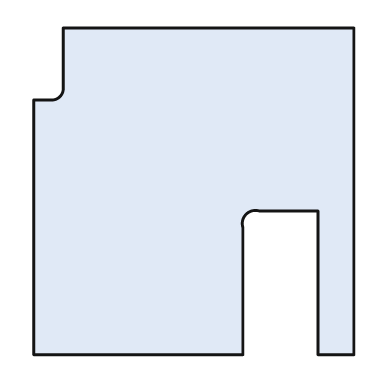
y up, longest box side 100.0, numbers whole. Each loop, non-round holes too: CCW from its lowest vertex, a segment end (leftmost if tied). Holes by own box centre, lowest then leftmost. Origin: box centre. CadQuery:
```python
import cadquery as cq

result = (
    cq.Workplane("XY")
    .moveTo(-49.0, -50.0)
    .lineTo(15.0, -50.0)
    .lineTo(15.0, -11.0)
    .threePointArc((16.0, -7.0), (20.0, -6.0))
    .lineTo(38.0, -6.0)
    .lineTo(38.0, -50.0)
    .lineTo(49.0, -50.0)
    .lineTo(49.0, 50.0)
    .lineTo(-40.0, 50.0)
    .lineTo(-40.0, 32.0)
    .threePointArc((-41.0, 29.0), (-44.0, 28.0))
    .lineTo(-49.0, 28.0)
    .close()
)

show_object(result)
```